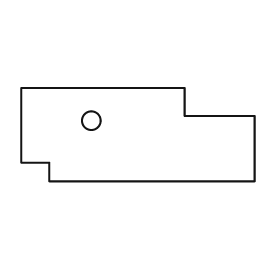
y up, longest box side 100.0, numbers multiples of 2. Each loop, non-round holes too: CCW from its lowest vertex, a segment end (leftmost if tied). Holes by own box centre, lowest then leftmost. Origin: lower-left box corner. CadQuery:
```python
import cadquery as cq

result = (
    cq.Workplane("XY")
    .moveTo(12.0, 0.0)
    .lineTo(100.0, 0.0)
    .lineTo(100.0, 28.0)
    .lineTo(70.0, 28.0)
    .lineTo(70.0, 40.0)
    .lineTo(0.0, 40.0)
    .lineTo(0.0, 8.0)
    .lineTo(12.0, 8.0)
    .close()
    .moveTo(30.0, 26.0)
    .circle(4.0)
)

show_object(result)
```